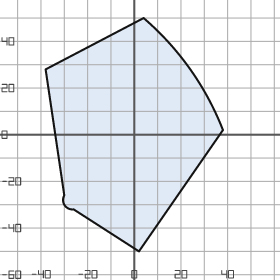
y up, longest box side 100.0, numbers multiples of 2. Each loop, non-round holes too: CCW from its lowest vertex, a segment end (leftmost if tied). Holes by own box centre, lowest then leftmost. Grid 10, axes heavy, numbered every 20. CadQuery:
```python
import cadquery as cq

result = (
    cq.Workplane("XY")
    .moveTo(2.0, -50.0)
    .lineTo(38.0, 2.0)
    .threePointArc((24.0, 28.0), (4.0, 50.0))
    .lineTo(-38.0, 28.0)
    .lineTo(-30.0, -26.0)
    .threePointArc((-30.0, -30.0), (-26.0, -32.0))
    .close()
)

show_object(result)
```